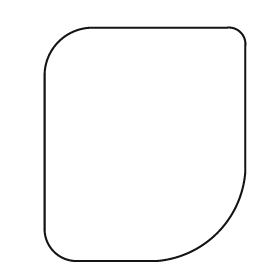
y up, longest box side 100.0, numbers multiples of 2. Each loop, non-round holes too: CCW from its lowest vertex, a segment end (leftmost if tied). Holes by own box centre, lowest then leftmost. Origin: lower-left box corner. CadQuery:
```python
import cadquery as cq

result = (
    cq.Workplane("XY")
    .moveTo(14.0, 0.0)
    .lineTo(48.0, 0.0)
    .threePointArc((74.0, 12.0), (86.0, 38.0))
    .lineTo(86.0, 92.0)
    .threePointArc((84.0, 98.0), (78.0, 100.0))
    .lineTo(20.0, 100.0)
    .threePointArc((6.0, 94.0), (0.0, 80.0))
    .lineTo(0.0, 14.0)
    .threePointArc((4.0, 4.0), (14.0, 0.0))
    .close()
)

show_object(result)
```